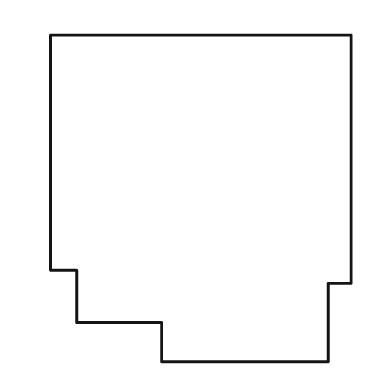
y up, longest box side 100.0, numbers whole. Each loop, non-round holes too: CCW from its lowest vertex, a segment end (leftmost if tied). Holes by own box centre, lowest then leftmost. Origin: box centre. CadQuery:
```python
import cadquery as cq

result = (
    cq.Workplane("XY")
    .moveTo(-12.0, -50.0)
    .lineTo(39.0, -50.0)
    .lineTo(39.0, -26.0)
    .lineTo(46.0, -26.0)
    .lineTo(46.0, 50.0)
    .lineTo(-46.0, 50.0)
    .lineTo(-46.0, -22.0)
    .lineTo(-38.0, -22.0)
    .lineTo(-38.0, -38.0)
    .lineTo(-12.0, -38.0)
    .close()
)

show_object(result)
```